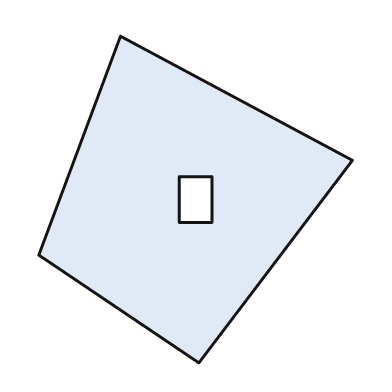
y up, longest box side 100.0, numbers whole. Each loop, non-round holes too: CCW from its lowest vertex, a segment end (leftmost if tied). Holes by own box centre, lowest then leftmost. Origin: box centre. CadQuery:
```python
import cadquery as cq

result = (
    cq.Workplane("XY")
    .moveTo(1.0, -50.0)
    .lineTo(48.0, 12.0)
    .lineTo(-23.0, 50.0)
    .lineTo(-48.0, -17.0)
    .close()
    .moveTo(-5.0, -7.0)
    .lineTo(5.0, -7.0)
    .lineTo(5.0, 7.0)
    .lineTo(-5.0, 7.0)
    .close()
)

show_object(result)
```